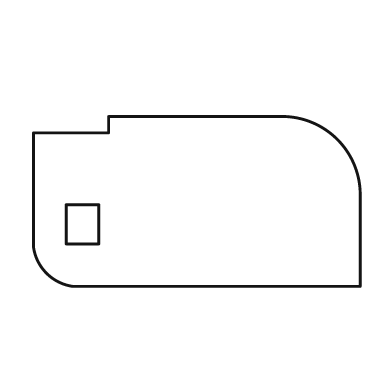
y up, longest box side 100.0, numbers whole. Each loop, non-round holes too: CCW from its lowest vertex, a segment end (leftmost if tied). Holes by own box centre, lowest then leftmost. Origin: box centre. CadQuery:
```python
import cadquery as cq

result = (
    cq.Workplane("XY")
    .moveTo(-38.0, -26.0)
    .lineTo(50.0, -26.0)
    .lineTo(50.0, 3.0)
    .threePointArc((43.0, 19.0), (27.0, 26.0))
    .lineTo(-27.0, 26.0)
    .lineTo(-27.0, 21.0)
    .lineTo(-50.0, 21.0)
    .lineTo(-50.0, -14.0)
    .threePointArc((-46.0, -22.0), (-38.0, -26.0))
    .close()
    .moveTo(-40.0, -13.0)
    .lineTo(-30.0, -13.0)
    .lineTo(-30.0, -1.0)
    .lineTo(-40.0, -1.0)
    .close()
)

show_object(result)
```